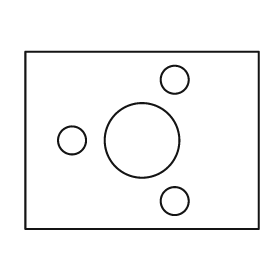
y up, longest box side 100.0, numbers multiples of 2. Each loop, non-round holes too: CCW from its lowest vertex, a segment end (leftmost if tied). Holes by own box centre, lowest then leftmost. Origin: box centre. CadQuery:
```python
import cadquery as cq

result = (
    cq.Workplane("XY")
    .moveTo(-50.0, -38.0)
    .lineTo(50.0, -38.0)
    .lineTo(50.0, 38.0)
    .lineTo(-50.0, 38.0)
    .close()
    .moveTo(14.0, -26.0)
    .circle(6.0)
    .moveTo(-30.0, 0.0)
    .circle(6.0)
    .moveTo(0.0, 0.0)
    .circle(16.0)
    .moveTo(14.0, 26.0)
    .circle(6.0)
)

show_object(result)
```